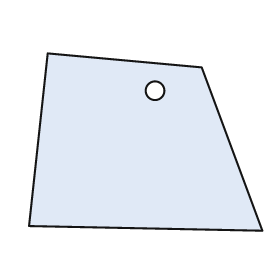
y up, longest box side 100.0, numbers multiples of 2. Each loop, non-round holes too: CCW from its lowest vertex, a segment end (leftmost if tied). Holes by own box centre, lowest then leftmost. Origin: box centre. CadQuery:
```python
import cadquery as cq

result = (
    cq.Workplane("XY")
    .moveTo(50.0, -38.0)
    .lineTo(24.0, 32.0)
    .lineTo(-42.0, 38.0)
    .lineTo(-50.0, -36.0)
    .close()
    .moveTo(4.0, 22.0)
    .circle(4.0)
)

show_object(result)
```